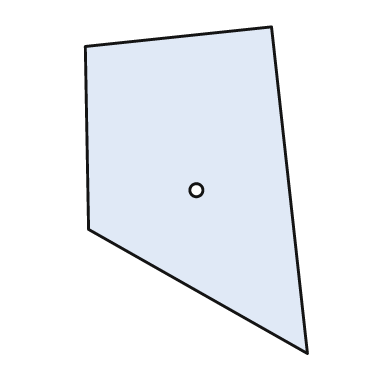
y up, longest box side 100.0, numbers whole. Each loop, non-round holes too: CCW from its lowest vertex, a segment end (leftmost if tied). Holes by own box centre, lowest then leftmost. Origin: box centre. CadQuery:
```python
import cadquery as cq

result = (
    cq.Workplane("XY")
    .moveTo(34.0, -50.0)
    .lineTo(23.0, 50.0)
    .lineTo(-34.0, 44.0)
    .lineTo(-33.0, -12.0)
    .close()
    .moveTo(0.0, 0.0)
    .circle(2.0)
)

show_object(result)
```